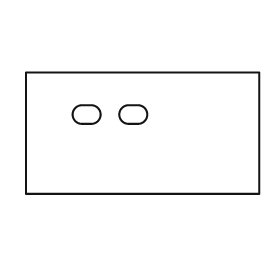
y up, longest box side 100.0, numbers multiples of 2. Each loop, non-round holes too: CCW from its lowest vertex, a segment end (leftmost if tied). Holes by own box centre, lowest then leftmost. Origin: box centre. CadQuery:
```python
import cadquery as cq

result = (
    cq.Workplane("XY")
    .moveTo(-50.0, -26.0)
    .lineTo(50.0, -26.0)
    .lineTo(50.0, 26.0)
    .lineTo(-50.0, 26.0)
    .close()
    .moveTo(-26.0, 4.0)
    .lineTo(-22.0, 4.0)
    .threePointArc((-18.0, 8.0), (-22.0, 12.0))
    .lineTo(-26.0, 12.0)
    .threePointArc((-30.0, 8.0), (-26.0, 4.0))
    .close()
    .moveTo(-6.0, 4.0)
    .lineTo(-2.0, 4.0)
    .threePointArc((2.0, 8.0), (-2.0, 12.0))
    .lineTo(-6.0, 12.0)
    .threePointArc((-10.0, 8.0), (-6.0, 4.0))
    .close()
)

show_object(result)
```